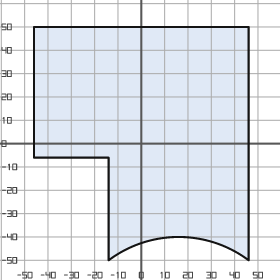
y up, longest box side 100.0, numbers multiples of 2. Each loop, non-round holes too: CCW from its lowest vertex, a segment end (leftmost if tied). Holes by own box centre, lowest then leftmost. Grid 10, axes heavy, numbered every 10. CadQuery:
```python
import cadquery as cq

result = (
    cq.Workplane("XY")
    .moveTo(-14.0, -50.0)
    .threePointArc((16.0, -40.0), (46.0, -50.0))
    .lineTo(46.0, 50.0)
    .lineTo(-46.0, 50.0)
    .lineTo(-46.0, -6.0)
    .lineTo(-14.0, -6.0)
    .close()
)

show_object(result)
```